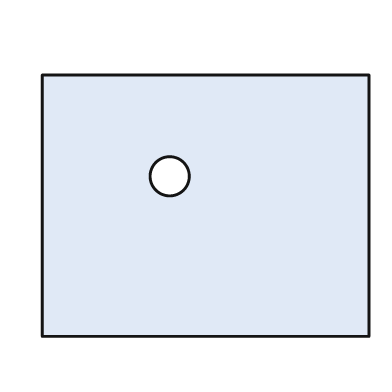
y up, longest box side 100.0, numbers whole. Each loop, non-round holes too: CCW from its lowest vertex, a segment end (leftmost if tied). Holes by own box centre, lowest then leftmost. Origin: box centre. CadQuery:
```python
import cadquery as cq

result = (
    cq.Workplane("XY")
    .moveTo(-50.0, -40.0)
    .lineTo(50.0, -40.0)
    .lineTo(50.0, 40.0)
    .lineTo(-50.0, 40.0)
    .close()
    .moveTo(-11.0, 9.0)
    .circle(6.0)
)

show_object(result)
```